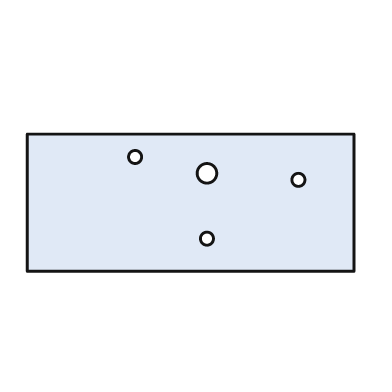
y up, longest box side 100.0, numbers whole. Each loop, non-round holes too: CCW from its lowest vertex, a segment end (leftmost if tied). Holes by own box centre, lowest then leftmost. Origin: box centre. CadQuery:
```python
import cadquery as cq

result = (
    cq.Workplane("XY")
    .moveTo(-50.0, -21.0)
    .lineTo(50.0, -21.0)
    .lineTo(50.0, 21.0)
    .lineTo(-50.0, 21.0)
    .close()
    .moveTo(5.0, -11.0)
    .circle(2.0)
    .moveTo(33.0, 7.0)
    .circle(2.0)
    .moveTo(5.0, 9.0)
    .circle(3.0)
    .moveTo(-17.0, 14.0)
    .circle(2.0)
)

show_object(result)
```